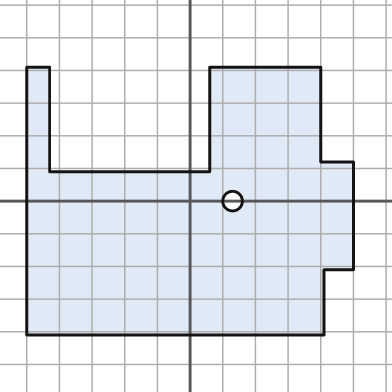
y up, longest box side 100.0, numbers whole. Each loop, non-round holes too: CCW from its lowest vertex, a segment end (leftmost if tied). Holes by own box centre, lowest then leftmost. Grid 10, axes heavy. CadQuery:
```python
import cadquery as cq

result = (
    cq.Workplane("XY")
    .moveTo(-50.0, -41.0)
    .lineTo(41.0, -41.0)
    .lineTo(41.0, -21.0)
    .lineTo(50.0, -21.0)
    .lineTo(50.0, 12.0)
    .lineTo(40.0, 12.0)
    .lineTo(40.0, 41.0)
    .lineTo(6.0, 41.0)
    .lineTo(6.0, 9.0)
    .lineTo(-43.0, 9.0)
    .lineTo(-43.0, 41.0)
    .lineTo(-50.0, 41.0)
    .close()
    .moveTo(13.0, 0.0)
    .circle(3.0)
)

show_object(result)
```